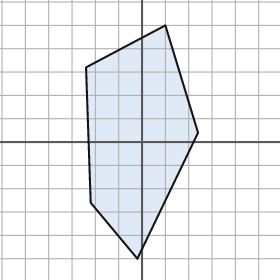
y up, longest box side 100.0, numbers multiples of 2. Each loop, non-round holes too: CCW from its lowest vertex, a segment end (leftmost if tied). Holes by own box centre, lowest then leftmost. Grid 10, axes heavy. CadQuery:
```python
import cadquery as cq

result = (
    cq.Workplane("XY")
    .moveTo(-2.0, -50.0)
    .lineTo(24.0, 4.0)
    .lineTo(10.0, 50.0)
    .lineTo(-24.0, 32.0)
    .lineTo(-22.0, -26.0)
    .close()
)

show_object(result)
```